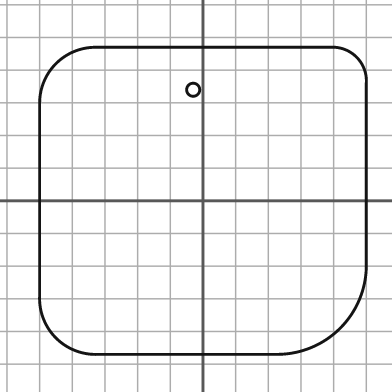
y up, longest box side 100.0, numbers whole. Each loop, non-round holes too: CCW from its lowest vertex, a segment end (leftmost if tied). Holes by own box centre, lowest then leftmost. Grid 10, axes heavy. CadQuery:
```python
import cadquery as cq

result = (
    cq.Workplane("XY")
    .moveTo(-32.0, -47.0)
    .lineTo(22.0, -47.0)
    .threePointArc((42.0, -39.0), (50.0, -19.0))
    .lineTo(50.0, 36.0)
    .threePointArc((47.0, 44.0), (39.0, 47.0))
    .lineTo(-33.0, 47.0)
    .threePointArc((-45.0, 42.0), (-50.0, 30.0))
    .lineTo(-50.0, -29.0)
    .threePointArc((-45.0, -42.0), (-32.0, -47.0))
    .close()
    .moveTo(-3.0, 34.0)
    .circle(2.0)
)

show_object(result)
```